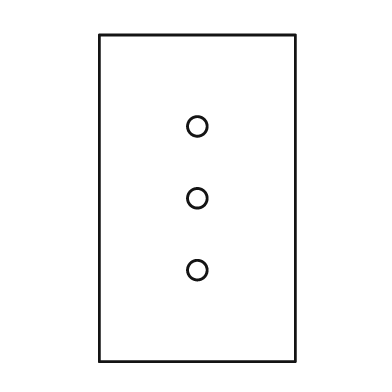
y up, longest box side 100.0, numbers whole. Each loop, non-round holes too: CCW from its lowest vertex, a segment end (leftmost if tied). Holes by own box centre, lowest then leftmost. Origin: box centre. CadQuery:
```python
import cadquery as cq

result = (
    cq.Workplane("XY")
    .moveTo(-30.0, -50.0)
    .lineTo(30.0, -50.0)
    .lineTo(30.0, 50.0)
    .lineTo(-30.0, 50.0)
    .close()
    .moveTo(0.0, -22.0)
    .circle(3.0)
    .moveTo(0.0, 0.0)
    .circle(3.0)
    .moveTo(0.0, 22.0)
    .circle(3.0)
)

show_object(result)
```